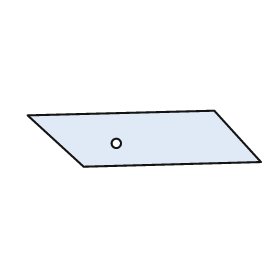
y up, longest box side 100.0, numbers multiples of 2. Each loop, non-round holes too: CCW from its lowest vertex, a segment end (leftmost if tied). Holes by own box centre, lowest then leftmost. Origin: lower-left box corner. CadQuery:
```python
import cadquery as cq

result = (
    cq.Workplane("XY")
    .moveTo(24.0, 0.0)
    .lineTo(100.0, 2.0)
    .lineTo(80.0, 24.0)
    .lineTo(0.0, 22.0)
    .close()
    .moveTo(38.0, 10.0)
    .circle(2.0)
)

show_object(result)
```